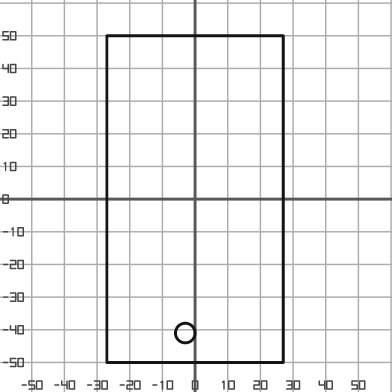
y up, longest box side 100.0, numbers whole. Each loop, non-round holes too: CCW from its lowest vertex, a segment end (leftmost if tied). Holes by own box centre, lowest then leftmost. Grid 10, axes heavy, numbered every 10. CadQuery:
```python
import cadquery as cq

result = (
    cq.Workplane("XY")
    .moveTo(-27.0, -50.0)
    .lineTo(27.0, -50.0)
    .lineTo(27.0, 50.0)
    .lineTo(-27.0, 50.0)
    .close()
    .moveTo(-3.0, -41.0)
    .circle(3.0)
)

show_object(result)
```